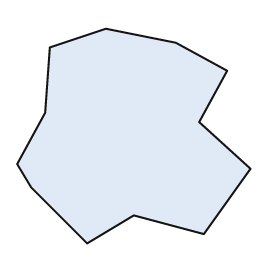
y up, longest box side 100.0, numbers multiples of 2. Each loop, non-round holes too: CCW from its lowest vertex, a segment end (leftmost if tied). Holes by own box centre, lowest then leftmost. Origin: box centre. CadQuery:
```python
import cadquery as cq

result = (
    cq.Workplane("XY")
    .moveTo(-20.0, -46.0)
    .lineTo(0.0, -34.0)
    .lineTo(30.0, -42.0)
    .lineTo(50.0, -14.0)
    .lineTo(28.0, 6.0)
    .lineTo(40.0, 28.0)
    .lineTo(18.0, 40.0)
    .lineTo(-12.0, 46.0)
    .lineTo(-36.0, 38.0)
    .lineTo(-38.0, 10.0)
    .lineTo(-50.0, -12.0)
    .lineTo(-44.0, -22.0)
    .close()
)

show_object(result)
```